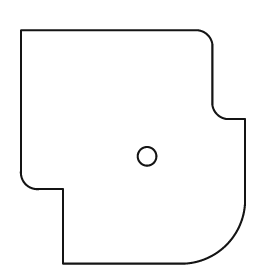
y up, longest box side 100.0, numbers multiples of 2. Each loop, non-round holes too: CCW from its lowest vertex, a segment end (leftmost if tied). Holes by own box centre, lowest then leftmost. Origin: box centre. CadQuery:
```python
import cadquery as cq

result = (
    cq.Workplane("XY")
    .moveTo(-30.0, -50.0)
    .lineTo(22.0, -50.0)
    .threePointArc((40.0, -42.0), (48.0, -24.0))
    .lineTo(48.0, 12.0)
    .lineTo(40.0, 12.0)
    .threePointArc((36.0, 14.0), (34.0, 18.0))
    .lineTo(34.0, 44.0)
    .threePointArc((32.0, 48.0), (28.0, 50.0))
    .lineTo(-48.0, 50.0)
    .lineTo(-48.0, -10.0)
    .threePointArc((-46.0, -16.0), (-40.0, -18.0))
    .lineTo(-30.0, -18.0)
    .close()
    .moveTo(6.0, -4.0)
    .circle(4.0)
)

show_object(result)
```